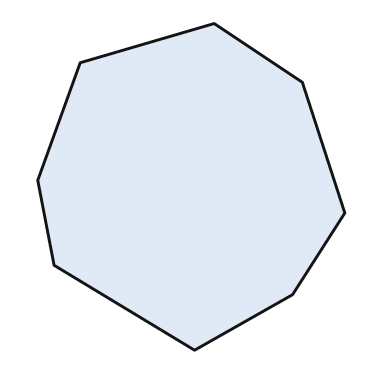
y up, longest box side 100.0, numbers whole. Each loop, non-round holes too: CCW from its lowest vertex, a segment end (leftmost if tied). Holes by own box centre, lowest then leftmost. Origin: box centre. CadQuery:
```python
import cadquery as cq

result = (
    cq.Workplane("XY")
    .moveTo(1.0, -50.0)
    .lineTo(31.0, -33.0)
    .lineTo(47.0, -8.0)
    .lineTo(34.0, 32.0)
    .lineTo(7.0, 50.0)
    .lineTo(-34.0, 38.0)
    .lineTo(-47.0, 2.0)
    .lineTo(-42.0, -24.0)
    .close()
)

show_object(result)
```